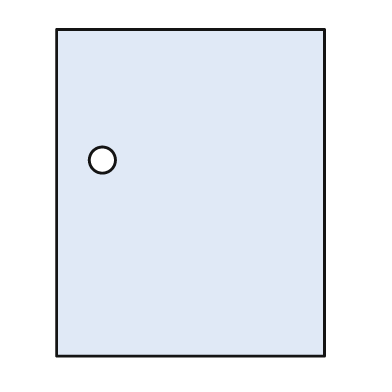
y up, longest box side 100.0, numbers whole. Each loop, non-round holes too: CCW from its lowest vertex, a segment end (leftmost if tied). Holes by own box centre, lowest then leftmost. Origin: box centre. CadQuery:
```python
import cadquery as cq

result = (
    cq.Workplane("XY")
    .moveTo(-41.0, -50.0)
    .lineTo(41.0, -50.0)
    .lineTo(41.0, 50.0)
    .lineTo(-41.0, 50.0)
    .close()
    .moveTo(-27.0, 10.0)
    .circle(4.0)
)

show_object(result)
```